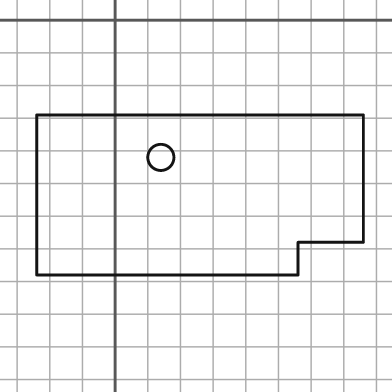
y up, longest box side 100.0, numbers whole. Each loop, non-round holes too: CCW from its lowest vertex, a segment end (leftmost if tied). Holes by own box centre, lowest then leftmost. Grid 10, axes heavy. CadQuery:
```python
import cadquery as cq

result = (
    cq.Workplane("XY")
    .moveTo(-24.0, -78.0)
    .lineTo(56.0, -78.0)
    .lineTo(56.0, -68.0)
    .lineTo(76.0, -68.0)
    .lineTo(76.0, -29.0)
    .lineTo(-24.0, -29.0)
    .close()
    .moveTo(14.0, -42.0)
    .circle(4.0)
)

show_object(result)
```